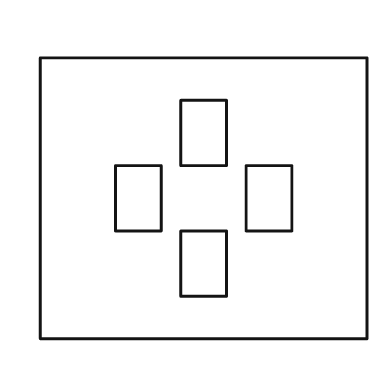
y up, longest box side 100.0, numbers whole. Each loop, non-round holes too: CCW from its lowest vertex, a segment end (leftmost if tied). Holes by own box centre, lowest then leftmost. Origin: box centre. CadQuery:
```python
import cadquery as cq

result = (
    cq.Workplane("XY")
    .moveTo(-50.0, -43.0)
    .lineTo(50.0, -43.0)
    .lineTo(50.0, 43.0)
    .lineTo(-50.0, 43.0)
    .close()
    .moveTo(-7.0, -30.0)
    .lineTo(7.0, -30.0)
    .lineTo(7.0, -10.0)
    .lineTo(-7.0, -10.0)
    .close()
    .moveTo(-27.0, -10.0)
    .lineTo(-13.0, -10.0)
    .lineTo(-13.0, 10.0)
    .lineTo(-27.0, 10.0)
    .close()
    .moveTo(13.0, -10.0)
    .lineTo(27.0, -10.0)
    .lineTo(27.0, 10.0)
    .lineTo(13.0, 10.0)
    .close()
    .moveTo(-7.0, 10.0)
    .lineTo(7.0, 10.0)
    .lineTo(7.0, 30.0)
    .lineTo(-7.0, 30.0)
    .close()
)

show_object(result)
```